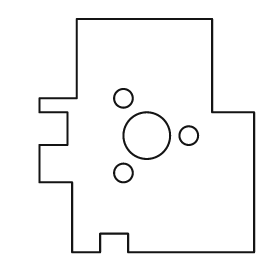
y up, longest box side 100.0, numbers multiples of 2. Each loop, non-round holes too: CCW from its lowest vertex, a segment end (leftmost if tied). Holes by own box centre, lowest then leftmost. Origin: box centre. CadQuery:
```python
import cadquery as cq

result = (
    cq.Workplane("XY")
    .moveTo(-32.0, -50.0)
    .lineTo(-20.0, -50.0)
    .lineTo(-20.0, -42.0)
    .lineTo(-8.0, -42.0)
    .lineTo(-8.0, -50.0)
    .lineTo(46.0, -50.0)
    .lineTo(46.0, 10.0)
    .lineTo(28.0, 10.0)
    .lineTo(28.0, 50.0)
    .lineTo(-30.0, 50.0)
    .lineTo(-30.0, 16.0)
    .lineTo(-46.0, 16.0)
    .lineTo(-46.0, 10.0)
    .lineTo(-34.0, 10.0)
    .lineTo(-34.0, -4.0)
    .lineTo(-46.0, -4.0)
    .lineTo(-46.0, -20.0)
    .lineTo(-32.0, -20.0)
    .close()
    .moveTo(-10.0, -16.0)
    .circle(4.0)
    .moveTo(0.0, 0.0)
    .circle(10.0)
    .moveTo(18.0, 0.0)
    .circle(4.0)
    .moveTo(-10.0, 16.0)
    .circle(4.0)
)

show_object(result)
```